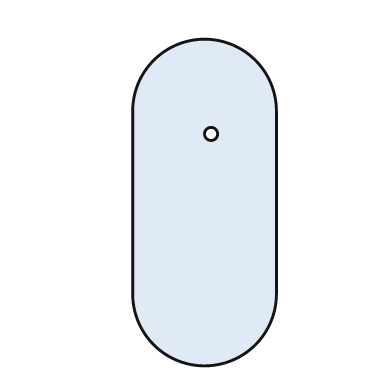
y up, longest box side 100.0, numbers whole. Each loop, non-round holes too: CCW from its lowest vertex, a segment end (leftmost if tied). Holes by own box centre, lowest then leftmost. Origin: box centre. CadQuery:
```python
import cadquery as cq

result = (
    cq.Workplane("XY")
    .moveTo(-22.0, -28.0)
    .threePointArc((0.0, -50.0), (22.0, -28.0))
    .lineTo(22.0, 28.0)
    .threePointArc((0.0, 50.0), (-22.0, 28.0))
    .close()
    .moveTo(2.0, 21.0)
    .circle(2.0)
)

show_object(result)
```